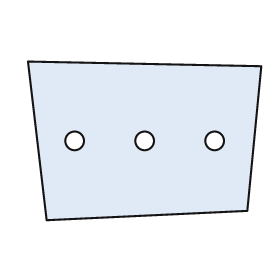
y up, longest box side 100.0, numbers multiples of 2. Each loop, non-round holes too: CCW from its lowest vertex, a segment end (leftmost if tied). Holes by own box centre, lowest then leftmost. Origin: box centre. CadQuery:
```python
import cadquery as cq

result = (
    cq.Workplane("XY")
    .moveTo(-42.0, -34.0)
    .lineTo(44.0, -30.0)
    .lineTo(50.0, 32.0)
    .lineTo(-50.0, 34.0)
    .close()
    .moveTo(-30.0, 0.0)
    .circle(4.0)
    .moveTo(0.0, 0.0)
    .circle(4.0)
    .moveTo(30.0, 0.0)
    .circle(4.0)
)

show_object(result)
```